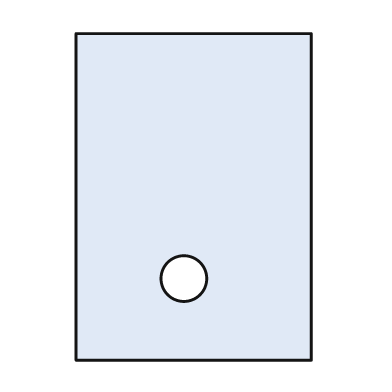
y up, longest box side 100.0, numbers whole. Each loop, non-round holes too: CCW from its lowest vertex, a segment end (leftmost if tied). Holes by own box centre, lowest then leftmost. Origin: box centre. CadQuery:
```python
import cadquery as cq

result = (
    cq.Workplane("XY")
    .moveTo(-36.0, -50.0)
    .lineTo(36.0, -50.0)
    .lineTo(36.0, 50.0)
    .lineTo(-36.0, 50.0)
    .close()
    .moveTo(-3.0, -25.0)
    .circle(7.0)
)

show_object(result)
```